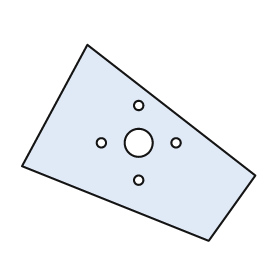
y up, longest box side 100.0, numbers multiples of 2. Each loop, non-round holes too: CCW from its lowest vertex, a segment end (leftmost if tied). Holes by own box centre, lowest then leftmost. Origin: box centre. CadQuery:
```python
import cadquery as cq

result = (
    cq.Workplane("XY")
    .moveTo(30.0, -42.0)
    .lineTo(50.0, -14.0)
    .lineTo(-22.0, 42.0)
    .lineTo(-50.0, -10.0)
    .close()
    .moveTo(0.0, -16.0)
    .circle(2.0)
    .moveTo(-16.0, 0.0)
    .circle(2.0)
    .moveTo(0.0, 0.0)
    .circle(6.0)
    .moveTo(16.0, 0.0)
    .circle(2.0)
    .moveTo(0.0, 16.0)
    .circle(2.0)
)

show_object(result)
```